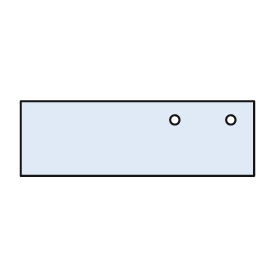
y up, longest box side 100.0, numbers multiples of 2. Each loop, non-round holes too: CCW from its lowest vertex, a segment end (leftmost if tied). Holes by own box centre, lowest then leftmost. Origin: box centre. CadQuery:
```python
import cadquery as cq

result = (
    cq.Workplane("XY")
    .moveTo(-50.0, -16.0)
    .lineTo(50.0, -16.0)
    .lineTo(50.0, 16.0)
    .lineTo(-50.0, 16.0)
    .close()
    .moveTo(16.0, 8.0)
    .circle(2.0)
    .moveTo(40.0, 8.0)
    .circle(2.0)
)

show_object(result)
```